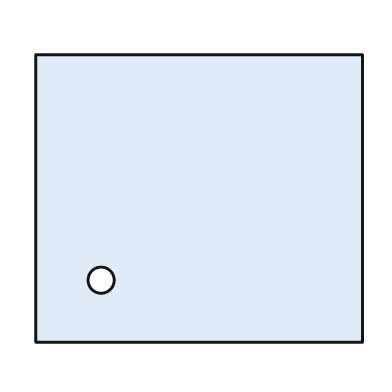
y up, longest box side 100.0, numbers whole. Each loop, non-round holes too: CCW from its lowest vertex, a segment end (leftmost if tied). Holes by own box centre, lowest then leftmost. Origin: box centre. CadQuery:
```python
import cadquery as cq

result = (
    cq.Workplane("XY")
    .moveTo(-50.0, -44.0)
    .lineTo(50.0, -44.0)
    .lineTo(50.0, 44.0)
    .lineTo(-50.0, 44.0)
    .close()
    .moveTo(-30.0, -25.0)
    .circle(4.0)
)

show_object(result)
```